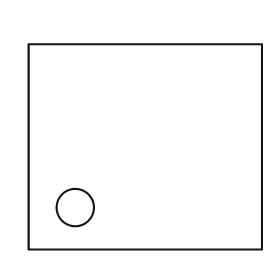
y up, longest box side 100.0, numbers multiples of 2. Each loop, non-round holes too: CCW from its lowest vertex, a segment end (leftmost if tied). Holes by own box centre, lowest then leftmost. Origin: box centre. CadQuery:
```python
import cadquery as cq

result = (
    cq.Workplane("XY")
    .moveTo(-50.0, -44.0)
    .lineTo(50.0, -44.0)
    .lineTo(50.0, 44.0)
    .lineTo(-50.0, 44.0)
    .close()
    .moveTo(-30.0, -26.0)
    .circle(8.0)
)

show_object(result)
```